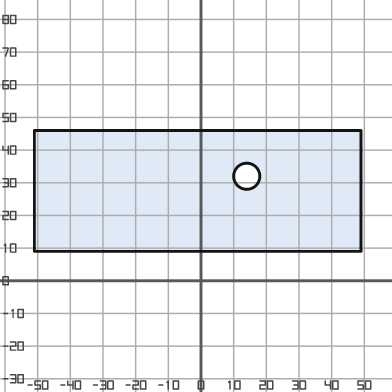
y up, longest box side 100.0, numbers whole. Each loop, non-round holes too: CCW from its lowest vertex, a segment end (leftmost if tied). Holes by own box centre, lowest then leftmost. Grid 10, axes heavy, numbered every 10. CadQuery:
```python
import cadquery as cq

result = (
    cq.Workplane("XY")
    .moveTo(-51.0, 9.0)
    .lineTo(49.0, 9.0)
    .lineTo(49.0, 46.0)
    .lineTo(-51.0, 46.0)
    .close()
    .moveTo(14.0, 32.0)
    .circle(4.0)
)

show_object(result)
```